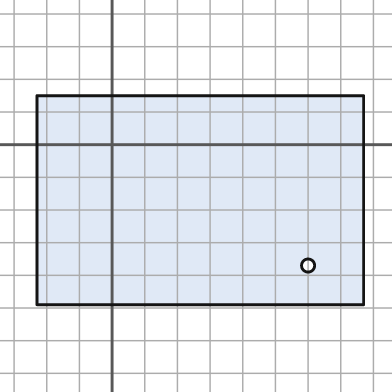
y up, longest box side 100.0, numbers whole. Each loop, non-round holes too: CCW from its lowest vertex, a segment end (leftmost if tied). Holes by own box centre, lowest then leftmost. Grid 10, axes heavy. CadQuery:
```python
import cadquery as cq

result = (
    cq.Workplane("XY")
    .moveTo(-23.0, -49.0)
    .lineTo(77.0, -49.0)
    .lineTo(77.0, 15.0)
    .lineTo(-23.0, 15.0)
    .close()
    .moveTo(60.0, -37.0)
    .circle(2.0)
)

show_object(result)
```